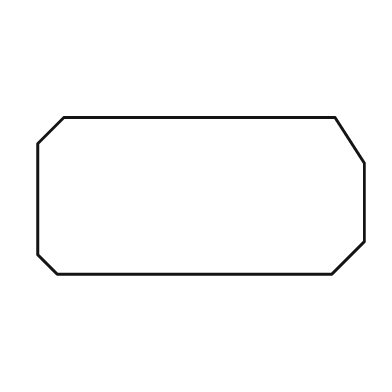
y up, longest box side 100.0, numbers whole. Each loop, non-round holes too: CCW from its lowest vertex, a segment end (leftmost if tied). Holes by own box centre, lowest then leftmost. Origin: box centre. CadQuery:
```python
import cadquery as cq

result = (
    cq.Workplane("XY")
    .moveTo(-44.0, -24.0)
    .lineTo(40.0, -24.0)
    .lineTo(50.0, -14.0)
    .lineTo(50.0, 10.0)
    .lineTo(41.0, 24.0)
    .lineTo(-42.0, 24.0)
    .lineTo(-50.0, 16.0)
    .lineTo(-50.0, -18.0)
    .close()
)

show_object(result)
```